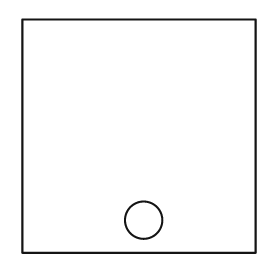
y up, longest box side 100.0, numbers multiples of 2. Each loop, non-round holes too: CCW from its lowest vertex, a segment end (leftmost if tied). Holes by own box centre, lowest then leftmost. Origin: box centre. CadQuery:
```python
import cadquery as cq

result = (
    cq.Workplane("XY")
    .moveTo(-50.0, -50.0)
    .lineTo(50.0, -50.0)
    .lineTo(50.0, 50.0)
    .lineTo(-50.0, 50.0)
    .close()
    .moveTo(2.0, -36.0)
    .circle(8.0)
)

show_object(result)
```